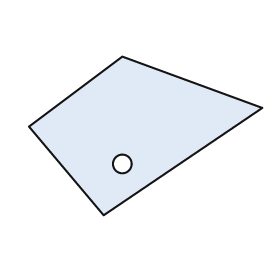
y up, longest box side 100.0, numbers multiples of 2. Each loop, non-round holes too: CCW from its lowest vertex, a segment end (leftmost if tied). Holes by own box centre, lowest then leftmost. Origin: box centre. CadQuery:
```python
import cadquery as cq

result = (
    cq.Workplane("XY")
    .moveTo(-18.0, -34.0)
    .lineTo(50.0, 12.0)
    .lineTo(-10.0, 34.0)
    .lineTo(-50.0, 4.0)
    .close()
    .moveTo(-10.0, -12.0)
    .circle(4.0)
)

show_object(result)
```